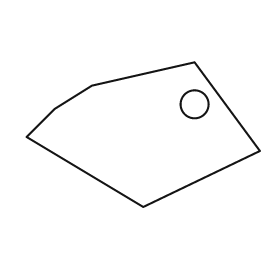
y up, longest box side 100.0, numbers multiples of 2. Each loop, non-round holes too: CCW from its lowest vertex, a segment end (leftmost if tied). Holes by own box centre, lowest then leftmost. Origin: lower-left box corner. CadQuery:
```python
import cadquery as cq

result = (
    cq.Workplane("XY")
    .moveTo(50.0, 0.0)
    .lineTo(100.0, 24.0)
    .lineTo(72.0, 62.0)
    .lineTo(28.0, 52.0)
    .lineTo(12.0, 42.0)
    .lineTo(0.0, 30.0)
    .close()
    .moveTo(72.0, 44.0)
    .circle(6.0)
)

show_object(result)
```